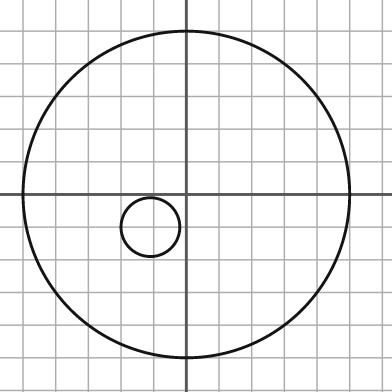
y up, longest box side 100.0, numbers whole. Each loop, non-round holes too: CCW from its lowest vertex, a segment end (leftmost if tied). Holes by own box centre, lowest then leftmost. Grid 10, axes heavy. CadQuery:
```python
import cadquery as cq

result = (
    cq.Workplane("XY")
    .moveTo(0.0, 0.0)
    .circle(50.0)
    .moveTo(-11.0, -10.0)
    .circle(9.0)
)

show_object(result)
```